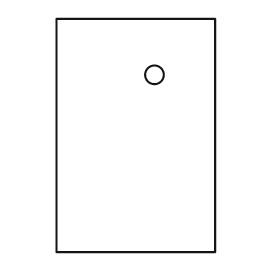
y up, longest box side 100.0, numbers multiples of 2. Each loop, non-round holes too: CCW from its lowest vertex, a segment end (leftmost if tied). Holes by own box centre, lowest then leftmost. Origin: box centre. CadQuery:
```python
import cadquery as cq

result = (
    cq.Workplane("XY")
    .moveTo(-34.0, -50.0)
    .lineTo(34.0, -50.0)
    .lineTo(34.0, 50.0)
    .lineTo(-34.0, 50.0)
    .close()
    .moveTo(8.0, 26.0)
    .circle(4.0)
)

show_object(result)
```